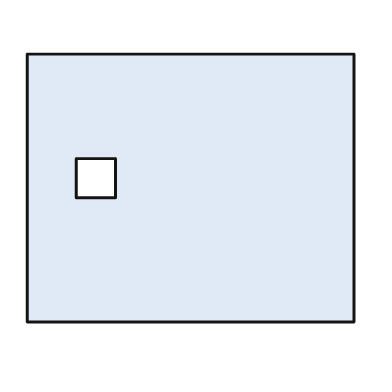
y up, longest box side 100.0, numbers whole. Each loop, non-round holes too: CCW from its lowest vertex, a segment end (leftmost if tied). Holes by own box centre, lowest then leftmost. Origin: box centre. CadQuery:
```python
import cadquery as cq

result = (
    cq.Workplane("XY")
    .moveTo(-50.0, -41.0)
    .lineTo(50.0, -41.0)
    .lineTo(50.0, 41.0)
    .lineTo(-50.0, 41.0)
    .close()
    .moveTo(-35.0, -3.0)
    .lineTo(-23.0, -3.0)
    .lineTo(-23.0, 9.0)
    .lineTo(-35.0, 9.0)
    .close()
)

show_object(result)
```